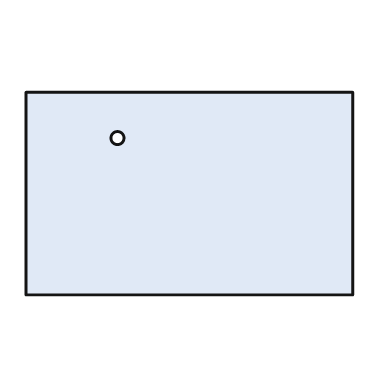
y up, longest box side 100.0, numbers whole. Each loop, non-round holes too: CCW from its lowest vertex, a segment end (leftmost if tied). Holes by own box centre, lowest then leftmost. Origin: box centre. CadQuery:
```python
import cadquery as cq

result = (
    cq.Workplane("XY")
    .moveTo(-50.0, -31.0)
    .lineTo(50.0, -31.0)
    .lineTo(50.0, 31.0)
    .lineTo(-50.0, 31.0)
    .close()
    .moveTo(-22.0, 17.0)
    .circle(2.0)
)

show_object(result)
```